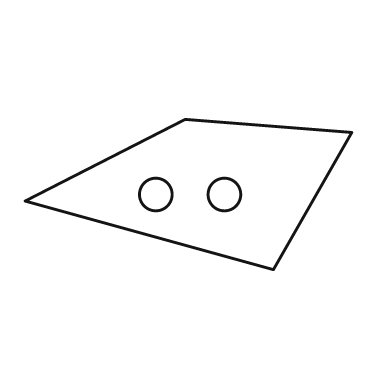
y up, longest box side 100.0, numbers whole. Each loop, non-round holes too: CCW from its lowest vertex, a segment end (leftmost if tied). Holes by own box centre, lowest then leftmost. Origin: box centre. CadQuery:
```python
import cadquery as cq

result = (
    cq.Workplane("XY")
    .moveTo(26.0, -23.0)
    .lineTo(50.0, 19.0)
    .lineTo(-1.0, 23.0)
    .lineTo(-50.0, -2.0)
    .close()
    .moveTo(-10.0, 0.0)
    .circle(5.0)
    .moveTo(11.0, 0.0)
    .circle(5.0)
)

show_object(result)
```